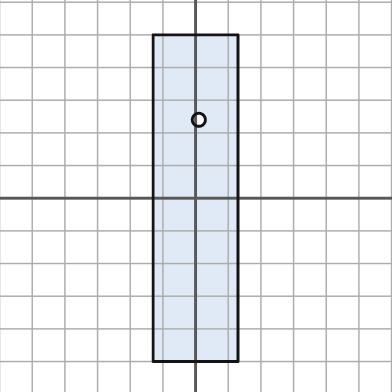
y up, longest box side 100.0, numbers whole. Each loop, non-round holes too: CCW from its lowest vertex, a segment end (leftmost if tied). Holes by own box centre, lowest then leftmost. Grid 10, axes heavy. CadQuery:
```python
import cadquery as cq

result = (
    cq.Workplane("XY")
    .moveTo(-13.0, -50.0)
    .lineTo(13.0, -50.0)
    .lineTo(13.0, 50.0)
    .lineTo(-13.0, 50.0)
    .close()
    .moveTo(1.0, 24.0)
    .circle(2.0)
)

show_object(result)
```